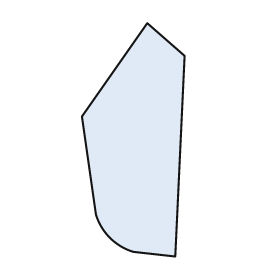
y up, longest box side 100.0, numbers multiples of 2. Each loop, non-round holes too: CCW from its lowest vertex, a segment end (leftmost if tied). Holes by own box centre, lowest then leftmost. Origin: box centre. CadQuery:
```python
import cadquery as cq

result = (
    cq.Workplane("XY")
    .moveTo(18.0, -50.0)
    .lineTo(22.0, 36.0)
    .lineTo(6.0, 50.0)
    .lineTo(-22.0, 10.0)
    .lineTo(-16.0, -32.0)
    .threePointArc((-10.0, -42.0), (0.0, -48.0))
    .close()
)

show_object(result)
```